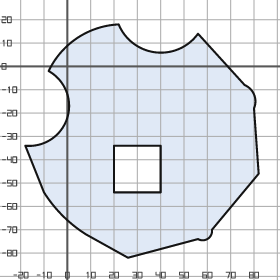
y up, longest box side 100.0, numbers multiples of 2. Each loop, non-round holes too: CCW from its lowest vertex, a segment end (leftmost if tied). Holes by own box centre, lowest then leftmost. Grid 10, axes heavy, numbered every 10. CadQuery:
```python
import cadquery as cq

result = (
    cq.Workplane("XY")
    .moveTo(26.0, -82.0)
    .lineTo(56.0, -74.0)
    .threePointArc((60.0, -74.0), (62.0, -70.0))
    .lineTo(82.0, -46.0)
    .lineTo(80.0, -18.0)
    .threePointArc((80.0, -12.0), (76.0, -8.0))
    .lineTo(56.0, 14.0)
    .threePointArc((38.0, 6.0), (22.0, 18.0))
    .threePointArc((4.0, 12.0), (-8.0, -2.0))
    .threePointArc((0.0, -22.0), (-18.0, -34.0))
    .lineTo(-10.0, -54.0)
    .threePointArc((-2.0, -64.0), (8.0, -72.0))
    .close()
    .moveTo(20.0, -54.0)
    .lineTo(40.0, -54.0)
    .lineTo(40.0, -34.0)
    .lineTo(20.0, -34.0)
    .close()
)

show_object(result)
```